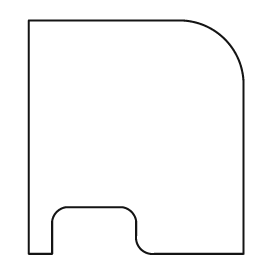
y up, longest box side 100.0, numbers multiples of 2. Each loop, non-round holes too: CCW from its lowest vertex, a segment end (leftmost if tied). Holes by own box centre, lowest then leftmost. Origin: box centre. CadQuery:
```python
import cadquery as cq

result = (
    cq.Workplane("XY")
    .moveTo(-46.0, -50.0)
    .lineTo(-36.0, -50.0)
    .lineTo(-36.0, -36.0)
    .threePointArc((-34.0, -32.0), (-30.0, -30.0))
    .lineTo(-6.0, -30.0)
    .threePointArc((-2.0, -32.0), (0.0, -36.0))
    .lineTo(0.0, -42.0)
    .threePointArc((2.0, -48.0), (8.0, -50.0))
    .lineTo(46.0, -50.0)
    .lineTo(46.0, 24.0)
    .threePointArc((38.0, 42.0), (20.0, 50.0))
    .lineTo(-46.0, 50.0)
    .close()
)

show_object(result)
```